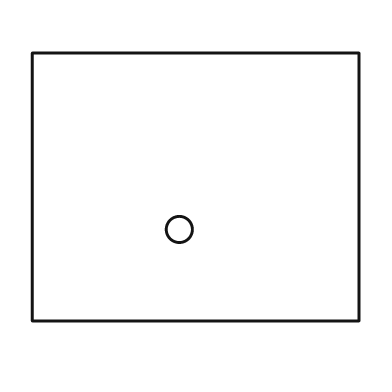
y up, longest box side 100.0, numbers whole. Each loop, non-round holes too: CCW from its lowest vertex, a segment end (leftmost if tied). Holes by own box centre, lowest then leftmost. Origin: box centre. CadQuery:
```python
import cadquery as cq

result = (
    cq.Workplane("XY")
    .moveTo(-50.0, -41.0)
    .lineTo(50.0, -41.0)
    .lineTo(50.0, 41.0)
    .lineTo(-50.0, 41.0)
    .close()
    .moveTo(-5.0, -13.0)
    .circle(4.0)
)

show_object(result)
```